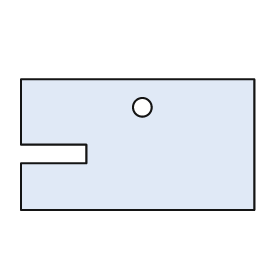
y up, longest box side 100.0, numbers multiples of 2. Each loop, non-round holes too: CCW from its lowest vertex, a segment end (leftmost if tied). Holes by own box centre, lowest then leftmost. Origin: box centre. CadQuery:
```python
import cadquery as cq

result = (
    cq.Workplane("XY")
    .moveTo(-50.0, -28.0)
    .lineTo(50.0, -28.0)
    .lineTo(50.0, 28.0)
    .lineTo(-50.0, 28.0)
    .lineTo(-50.0, 0.0)
    .lineTo(-22.0, 0.0)
    .lineTo(-22.0, -8.0)
    .lineTo(-50.0, -8.0)
    .close()
    .moveTo(2.0, 16.0)
    .circle(4.0)
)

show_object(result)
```